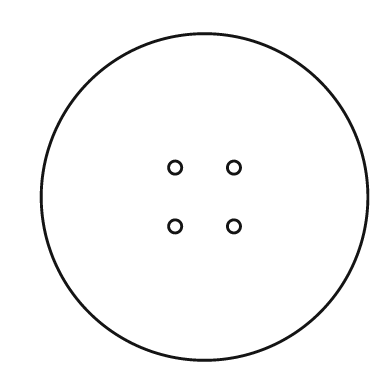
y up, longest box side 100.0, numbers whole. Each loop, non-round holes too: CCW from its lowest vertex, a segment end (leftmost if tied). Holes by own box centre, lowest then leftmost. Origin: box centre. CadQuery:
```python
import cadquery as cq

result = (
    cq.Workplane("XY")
    .moveTo(0.0, 0.0)
    .circle(50.0)
    .moveTo(-9.0, -9.0)
    .circle(2.0)
    .moveTo(9.0, -9.0)
    .circle(2.0)
    .moveTo(-9.0, 9.0)
    .circle(2.0)
    .moveTo(9.0, 9.0)
    .circle(2.0)
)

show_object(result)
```